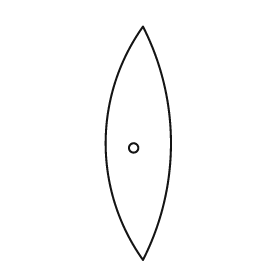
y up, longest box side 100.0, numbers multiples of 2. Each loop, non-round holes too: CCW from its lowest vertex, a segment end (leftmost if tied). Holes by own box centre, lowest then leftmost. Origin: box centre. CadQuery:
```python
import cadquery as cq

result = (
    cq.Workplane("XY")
    .moveTo(2.0, -50.0)
    .threePointArc((14.0, 0.0), (2.0, 50.0))
    .threePointArc((-14.0, 0.0), (2.0, -50.0))
    .close()
    .moveTo(-2.0, -2.0)
    .circle(2.0)
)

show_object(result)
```